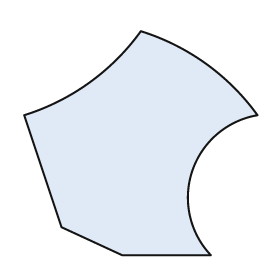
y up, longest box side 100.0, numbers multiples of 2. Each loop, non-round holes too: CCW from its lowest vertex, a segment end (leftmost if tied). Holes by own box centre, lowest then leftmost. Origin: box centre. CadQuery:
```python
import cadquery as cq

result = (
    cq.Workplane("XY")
    .moveTo(-8.0, -48.0)
    .lineTo(30.0, -48.0)
    .threePointArc((22.0, -12.0), (50.0, 12.0))
    .threePointArc((28.0, 34.0), (0.0, 48.0))
    .threePointArc((-22.0, 26.0), (-50.0, 12.0))
    .lineTo(-34.0, -36.0)
    .close()
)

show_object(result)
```